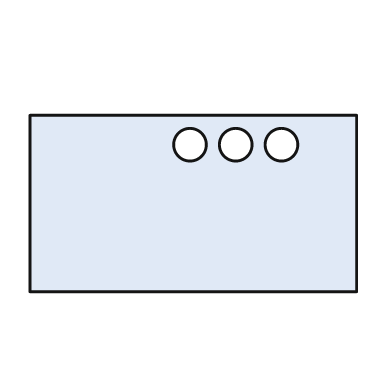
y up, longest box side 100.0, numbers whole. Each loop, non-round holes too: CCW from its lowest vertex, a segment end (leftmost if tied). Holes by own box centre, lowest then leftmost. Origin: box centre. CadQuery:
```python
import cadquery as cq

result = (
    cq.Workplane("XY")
    .moveTo(-50.0, -27.0)
    .lineTo(50.0, -27.0)
    .lineTo(50.0, 27.0)
    .lineTo(-50.0, 27.0)
    .close()
    .moveTo(-1.0, 18.0)
    .circle(5.0)
    .moveTo(13.0, 18.0)
    .circle(5.0)
    .moveTo(27.0, 18.0)
    .circle(5.0)
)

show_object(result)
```